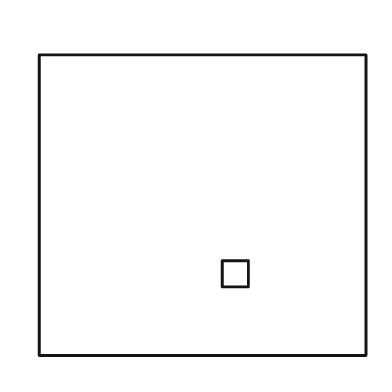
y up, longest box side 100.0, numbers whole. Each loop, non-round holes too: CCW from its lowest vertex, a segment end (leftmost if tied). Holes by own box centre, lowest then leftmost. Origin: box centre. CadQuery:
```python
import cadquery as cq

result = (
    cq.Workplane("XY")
    .moveTo(-50.0, -46.0)
    .lineTo(50.0, -46.0)
    .lineTo(50.0, 46.0)
    .lineTo(-50.0, 46.0)
    .close()
    .moveTo(6.0, -25.0)
    .lineTo(14.0, -25.0)
    .lineTo(14.0, -17.0)
    .lineTo(6.0, -17.0)
    .close()
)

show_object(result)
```